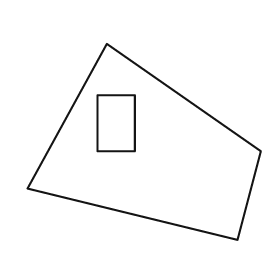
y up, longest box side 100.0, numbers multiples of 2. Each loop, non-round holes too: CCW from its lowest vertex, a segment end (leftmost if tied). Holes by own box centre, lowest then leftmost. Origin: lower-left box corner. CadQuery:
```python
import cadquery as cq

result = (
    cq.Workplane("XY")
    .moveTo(90.0, 0.0)
    .lineTo(100.0, 38.0)
    .lineTo(34.0, 84.0)
    .lineTo(0.0, 22.0)
    .close()
    .moveTo(30.0, 38.0)
    .lineTo(46.0, 38.0)
    .lineTo(46.0, 62.0)
    .lineTo(30.0, 62.0)
    .close()
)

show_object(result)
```